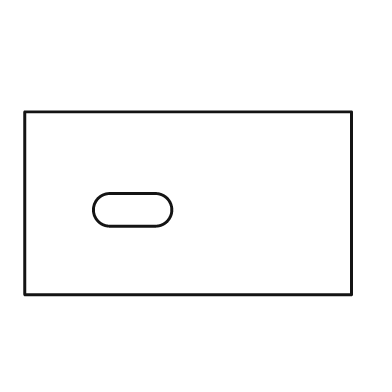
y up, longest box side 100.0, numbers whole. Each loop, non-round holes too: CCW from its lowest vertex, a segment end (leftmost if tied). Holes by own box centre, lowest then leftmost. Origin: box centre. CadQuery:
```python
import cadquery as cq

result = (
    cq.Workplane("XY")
    .moveTo(-50.0, -28.0)
    .lineTo(50.0, -28.0)
    .lineTo(50.0, 28.0)
    .lineTo(-50.0, 28.0)
    .close()
    .moveTo(-24.0, -7.0)
    .lineTo(-10.0, -7.0)
    .threePointArc((-5.0, -2.0), (-10.0, 3.0))
    .lineTo(-24.0, 3.0)
    .threePointArc((-29.0, -2.0), (-24.0, -7.0))
    .close()
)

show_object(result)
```